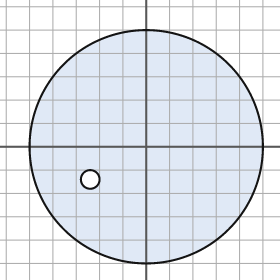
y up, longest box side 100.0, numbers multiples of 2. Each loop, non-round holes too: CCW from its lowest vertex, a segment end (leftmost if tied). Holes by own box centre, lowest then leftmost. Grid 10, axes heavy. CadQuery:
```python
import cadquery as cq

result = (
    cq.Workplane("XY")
    .moveTo(0.0, 0.0)
    .circle(50.0)
    .moveTo(-24.0, -14.0)
    .circle(4.0)
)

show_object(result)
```